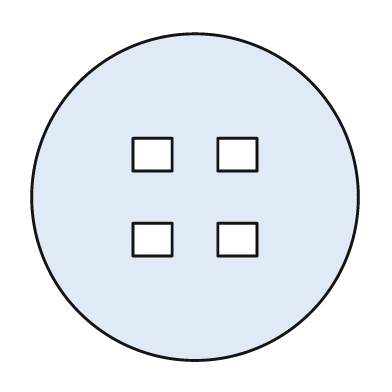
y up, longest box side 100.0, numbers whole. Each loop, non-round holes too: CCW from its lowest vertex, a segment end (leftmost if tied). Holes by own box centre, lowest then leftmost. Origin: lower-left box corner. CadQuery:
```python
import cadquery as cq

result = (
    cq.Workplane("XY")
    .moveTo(50.0, 50.0)
    .circle(50.0)
    .moveTo(31.0, 32.0)
    .lineTo(43.0, 32.0)
    .lineTo(43.0, 42.0)
    .lineTo(31.0, 42.0)
    .close()
    .moveTo(57.0, 32.0)
    .lineTo(69.0, 32.0)
    .lineTo(69.0, 42.0)
    .lineTo(57.0, 42.0)
    .close()
    .moveTo(31.0, 58.0)
    .lineTo(43.0, 58.0)
    .lineTo(43.0, 68.0)
    .lineTo(31.0, 68.0)
    .close()
    .moveTo(57.0, 58.0)
    .lineTo(69.0, 58.0)
    .lineTo(69.0, 68.0)
    .lineTo(57.0, 68.0)
    .close()
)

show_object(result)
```